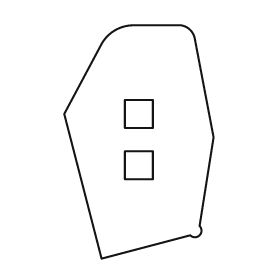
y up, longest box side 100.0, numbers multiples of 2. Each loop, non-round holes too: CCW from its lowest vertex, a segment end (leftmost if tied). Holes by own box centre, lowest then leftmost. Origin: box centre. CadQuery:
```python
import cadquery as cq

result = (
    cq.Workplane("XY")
    .moveTo(-16.0, -50.0)
    .lineTo(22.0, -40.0)
    .threePointArc((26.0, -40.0), (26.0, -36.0))
    .lineTo(32.0, 2.0)
    .lineTo(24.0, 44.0)
    .threePointArc((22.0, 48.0), (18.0, 50.0))
    .lineTo(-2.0, 50.0)
    .threePointArc((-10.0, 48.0), (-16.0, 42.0))
    .lineTo(-32.0, 12.0)
    .close()
    .moveTo(-6.0, -16.0)
    .lineTo(6.0, -16.0)
    .lineTo(6.0, -4.0)
    .lineTo(-6.0, -4.0)
    .close()
    .moveTo(-6.0, 6.0)
    .lineTo(6.0, 6.0)
    .lineTo(6.0, 18.0)
    .lineTo(-6.0, 18.0)
    .close()
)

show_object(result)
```